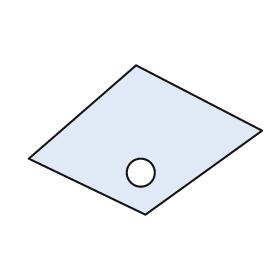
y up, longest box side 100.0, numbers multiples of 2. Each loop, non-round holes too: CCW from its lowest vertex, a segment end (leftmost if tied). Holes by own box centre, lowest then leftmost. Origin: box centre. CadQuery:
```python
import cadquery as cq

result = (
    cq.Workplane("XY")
    .moveTo(0.0, -32.0)
    .lineTo(50.0, 4.0)
    .lineTo(-4.0, 32.0)
    .lineTo(-50.0, -8.0)
    .close()
    .moveTo(-2.0, -14.0)
    .circle(6.0)
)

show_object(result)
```